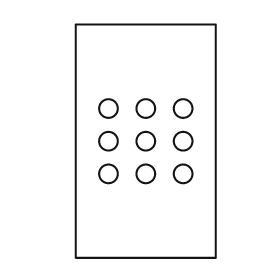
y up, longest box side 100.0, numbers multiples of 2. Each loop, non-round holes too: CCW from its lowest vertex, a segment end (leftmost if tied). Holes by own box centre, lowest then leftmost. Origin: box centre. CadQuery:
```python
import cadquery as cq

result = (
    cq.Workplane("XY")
    .moveTo(-30.0, -50.0)
    .lineTo(30.0, -50.0)
    .lineTo(30.0, 50.0)
    .lineTo(-30.0, 50.0)
    .close()
    .moveTo(-16.0, -14.0)
    .circle(4.0)
    .moveTo(0.0, -14.0)
    .circle(4.0)
    .moveTo(16.0, -14.0)
    .circle(4.0)
    .moveTo(-16.0, 0.0)
    .circle(4.0)
    .moveTo(0.0, 0.0)
    .circle(4.0)
    .moveTo(16.0, 0.0)
    .circle(4.0)
    .moveTo(-16.0, 14.0)
    .circle(4.0)
    .moveTo(0.0, 14.0)
    .circle(4.0)
    .moveTo(16.0, 14.0)
    .circle(4.0)
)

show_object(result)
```